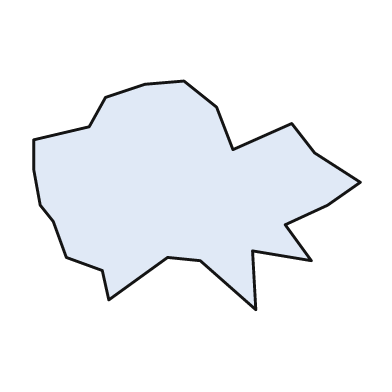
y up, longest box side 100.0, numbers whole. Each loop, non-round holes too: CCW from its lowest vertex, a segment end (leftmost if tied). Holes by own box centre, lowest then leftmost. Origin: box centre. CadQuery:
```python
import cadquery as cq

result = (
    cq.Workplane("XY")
    .moveTo(18.0, -35.0)
    .lineTo(17.0, -17.0)
    .lineTo(35.0, -20.0)
    .lineTo(27.0, -9.0)
    .lineTo(40.0, -3.0)
    .lineTo(50.0, 4.0)
    .lineTo(36.0, 13.0)
    .lineTo(29.0, 22.0)
    .lineTo(11.0, 14.0)
    .lineTo(6.0, 27.0)
    .lineTo(-4.0, 35.0)
    .lineTo(-16.0, 34.0)
    .lineTo(-28.0, 30.0)
    .lineTo(-33.0, 21.0)
    .lineTo(-50.0, 17.0)
    .lineTo(-50.0, 8.0)
    .lineTo(-48.0, -3.0)
    .lineTo(-44.0, -8.0)
    .lineTo(-40.0, -19.0)
    .lineTo(-29.0, -23.0)
    .lineTo(-27.0, -32.0)
    .lineTo(-9.0, -19.0)
    .lineTo(1.0, -20.0)
    .close()
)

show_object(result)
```